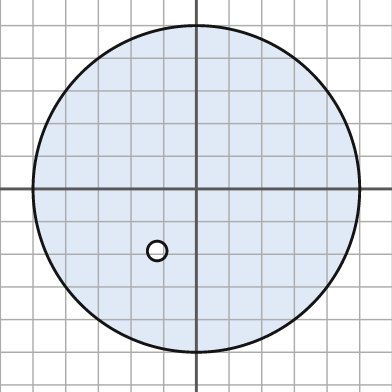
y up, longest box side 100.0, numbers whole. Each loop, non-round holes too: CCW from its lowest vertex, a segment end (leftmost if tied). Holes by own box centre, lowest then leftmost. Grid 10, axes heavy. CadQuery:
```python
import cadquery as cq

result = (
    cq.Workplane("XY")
    .moveTo(0.0, 0.0)
    .circle(50.0)
    .moveTo(-12.0, -19.0)
    .circle(3.0)
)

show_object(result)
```